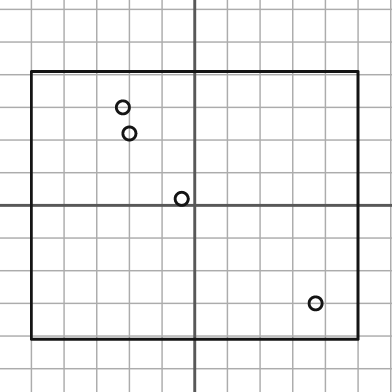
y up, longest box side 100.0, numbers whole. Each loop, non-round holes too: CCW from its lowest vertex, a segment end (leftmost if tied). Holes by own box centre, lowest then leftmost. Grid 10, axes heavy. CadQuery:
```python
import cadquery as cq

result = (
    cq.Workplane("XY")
    .moveTo(-50.0, -41.0)
    .lineTo(50.0, -41.0)
    .lineTo(50.0, 41.0)
    .lineTo(-50.0, 41.0)
    .close()
    .moveTo(37.0, -30.0)
    .circle(2.0)
    .moveTo(-4.0, 2.0)
    .circle(2.0)
    .moveTo(-20.0, 22.0)
    .circle(2.0)
    .moveTo(-22.0, 30.0)
    .circle(2.0)
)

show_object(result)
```